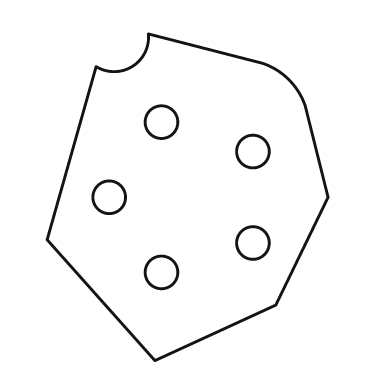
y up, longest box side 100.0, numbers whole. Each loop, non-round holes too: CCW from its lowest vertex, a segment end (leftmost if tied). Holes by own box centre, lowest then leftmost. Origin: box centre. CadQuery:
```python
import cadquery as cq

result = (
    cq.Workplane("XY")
    .moveTo(-10.0, -50.0)
    .lineTo(27.0, -33.0)
    .lineTo(43.0, 0.0)
    .lineTo(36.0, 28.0)
    .threePointArc((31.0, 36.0), (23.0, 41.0))
    .lineTo(-12.0, 50.0)
    .threePointArc((-17.0, 40.0), (-28.0, 40.0))
    .lineTo(-43.0, -13.0)
    .close()
    .moveTo(-8.0, -23.0)
    .circle(5.0)
    .moveTo(20.0, -14.0)
    .circle(5.0)
    .moveTo(-24.0, 0.0)
    .circle(5.0)
    .moveTo(20.0, 14.0)
    .circle(5.0)
    .moveTo(-8.0, 23.0)
    .circle(5.0)
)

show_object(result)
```